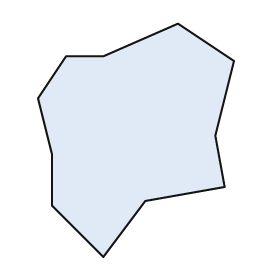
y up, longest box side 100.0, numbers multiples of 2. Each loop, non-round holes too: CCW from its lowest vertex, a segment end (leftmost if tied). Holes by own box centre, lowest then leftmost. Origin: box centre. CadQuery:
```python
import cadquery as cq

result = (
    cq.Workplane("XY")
    .moveTo(-14.0, -50.0)
    .lineTo(4.0, -26.0)
    .lineTo(38.0, -20.0)
    .lineTo(34.0, 2.0)
    .lineTo(42.0, 34.0)
    .lineTo(18.0, 50.0)
    .lineTo(-14.0, 36.0)
    .lineTo(-30.0, 36.0)
    .lineTo(-42.0, 18.0)
    .lineTo(-36.0, -6.0)
    .lineTo(-36.0, -28.0)
    .close()
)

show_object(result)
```